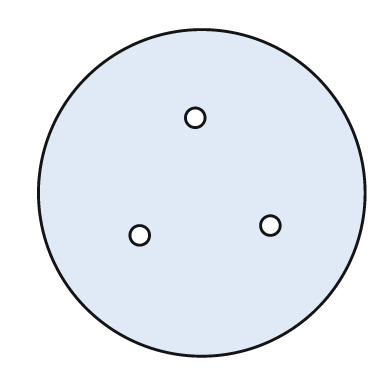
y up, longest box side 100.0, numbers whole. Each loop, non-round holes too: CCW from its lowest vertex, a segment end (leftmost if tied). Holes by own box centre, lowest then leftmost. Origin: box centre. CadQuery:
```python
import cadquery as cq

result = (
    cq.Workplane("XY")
    .moveTo(0.0, 0.0)
    .circle(50.0)
    .moveTo(-19.0, -13.0)
    .circle(3.0)
    .moveTo(21.0, -10.0)
    .circle(3.0)
    .moveTo(-2.0, 23.0)
    .circle(3.0)
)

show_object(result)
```